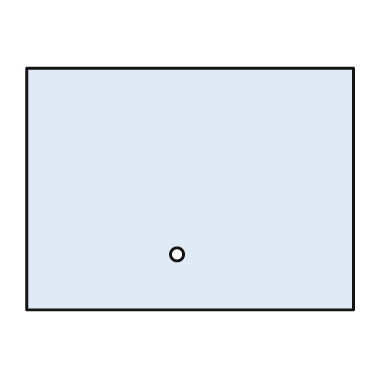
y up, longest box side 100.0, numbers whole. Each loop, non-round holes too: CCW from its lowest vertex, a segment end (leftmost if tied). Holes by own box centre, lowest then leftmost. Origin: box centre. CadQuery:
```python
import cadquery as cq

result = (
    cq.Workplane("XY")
    .moveTo(-50.0, -37.0)
    .lineTo(50.0, -37.0)
    .lineTo(50.0, 37.0)
    .lineTo(-50.0, 37.0)
    .close()
    .moveTo(-4.0, -20.0)
    .circle(2.0)
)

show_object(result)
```